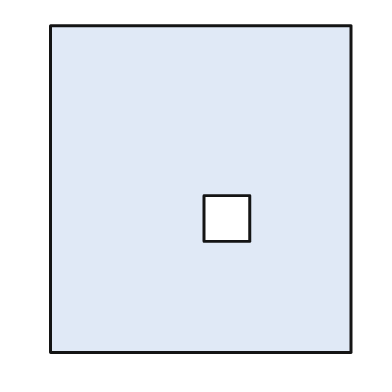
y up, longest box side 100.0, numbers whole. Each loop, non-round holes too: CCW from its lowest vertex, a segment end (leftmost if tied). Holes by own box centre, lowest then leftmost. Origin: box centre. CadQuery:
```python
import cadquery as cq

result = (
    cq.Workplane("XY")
    .moveTo(-46.0, -50.0)
    .lineTo(46.0, -50.0)
    .lineTo(46.0, 50.0)
    .lineTo(-46.0, 50.0)
    .close()
    .moveTo(1.0, -16.0)
    .lineTo(15.0, -16.0)
    .lineTo(15.0, -2.0)
    .lineTo(1.0, -2.0)
    .close()
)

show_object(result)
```